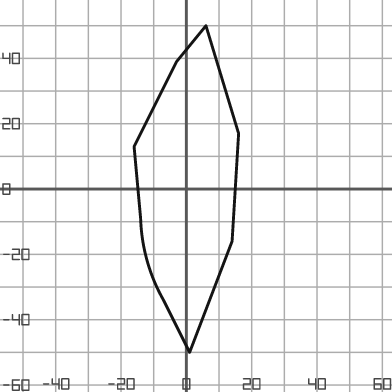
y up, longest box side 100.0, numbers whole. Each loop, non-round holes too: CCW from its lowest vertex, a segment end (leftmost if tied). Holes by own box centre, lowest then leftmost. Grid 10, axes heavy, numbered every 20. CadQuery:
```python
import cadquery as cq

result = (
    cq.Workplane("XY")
    .moveTo(1.0, -50.0)
    .lineTo(14.0, -16.0)
    .lineTo(16.0, 17.0)
    .lineTo(6.0, 50.0)
    .lineTo(-3.0, 39.0)
    .lineTo(-16.0, 13.0)
    .lineTo(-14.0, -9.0)
    .threePointArc((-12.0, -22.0), (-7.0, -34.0))
    .close()
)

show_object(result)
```